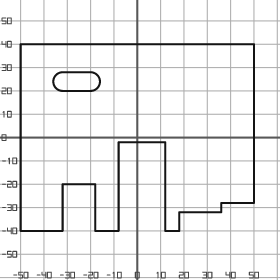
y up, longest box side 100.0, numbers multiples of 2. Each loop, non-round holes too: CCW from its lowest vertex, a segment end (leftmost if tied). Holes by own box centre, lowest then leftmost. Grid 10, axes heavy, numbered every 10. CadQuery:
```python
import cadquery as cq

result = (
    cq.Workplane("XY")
    .moveTo(-50.0, -40.0)
    .lineTo(-32.0, -40.0)
    .lineTo(-32.0, -20.0)
    .lineTo(-18.0, -20.0)
    .lineTo(-18.0, -40.0)
    .lineTo(-8.0, -40.0)
    .lineTo(-8.0, -2.0)
    .lineTo(12.0, -2.0)
    .lineTo(12.0, -40.0)
    .lineTo(18.0, -40.0)
    .lineTo(18.0, -32.0)
    .lineTo(36.0, -32.0)
    .lineTo(36.0, -28.0)
    .lineTo(50.0, -28.0)
    .lineTo(50.0, 40.0)
    .lineTo(-50.0, 40.0)
    .close()
    .moveTo(-32.0, 20.0)
    .lineTo(-20.0, 20.0)
    .threePointArc((-16.0, 24.0), (-20.0, 28.0))
    .lineTo(-32.0, 28.0)
    .threePointArc((-36.0, 24.0), (-32.0, 20.0))
    .close()
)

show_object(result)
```